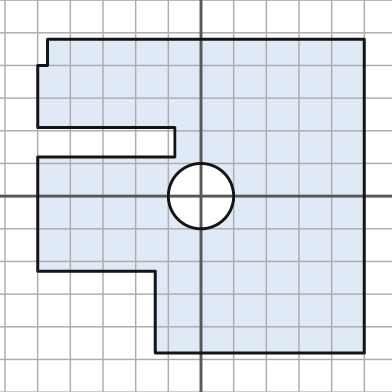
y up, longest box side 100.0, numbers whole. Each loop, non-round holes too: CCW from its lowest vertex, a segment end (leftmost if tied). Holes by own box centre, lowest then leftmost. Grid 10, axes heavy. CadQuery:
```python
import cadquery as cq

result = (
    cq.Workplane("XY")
    .moveTo(-14.0, -48.0)
    .lineTo(50.0, -48.0)
    .lineTo(50.0, 48.0)
    .lineTo(-47.0, 48.0)
    .lineTo(-47.0, 40.0)
    .lineTo(-50.0, 40.0)
    .lineTo(-50.0, 21.0)
    .lineTo(-8.0, 21.0)
    .lineTo(-8.0, 12.0)
    .lineTo(-50.0, 12.0)
    .lineTo(-50.0, -23.0)
    .lineTo(-14.0, -23.0)
    .close()
    .moveTo(0.0, 0.0)
    .circle(10.0)
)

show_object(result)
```